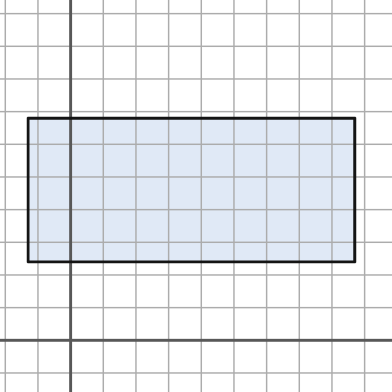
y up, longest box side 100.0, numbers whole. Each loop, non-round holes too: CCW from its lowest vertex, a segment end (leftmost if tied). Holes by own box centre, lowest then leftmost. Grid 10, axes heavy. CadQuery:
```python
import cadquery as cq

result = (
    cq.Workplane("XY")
    .moveTo(-13.0, 24.0)
    .lineTo(87.0, 24.0)
    .lineTo(87.0, 68.0)
    .lineTo(-13.0, 68.0)
    .close()
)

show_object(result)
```